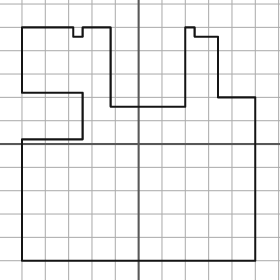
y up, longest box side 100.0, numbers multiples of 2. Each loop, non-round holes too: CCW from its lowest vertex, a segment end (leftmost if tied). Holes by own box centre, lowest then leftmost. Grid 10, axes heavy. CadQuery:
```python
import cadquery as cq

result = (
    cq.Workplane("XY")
    .moveTo(-50.0, -50.0)
    .lineTo(50.0, -50.0)
    .lineTo(50.0, 20.0)
    .lineTo(34.0, 20.0)
    .lineTo(34.0, 46.0)
    .lineTo(24.0, 46.0)
    .lineTo(24.0, 50.0)
    .lineTo(20.0, 50.0)
    .lineTo(20.0, 16.0)
    .lineTo(-12.0, 16.0)
    .lineTo(-12.0, 50.0)
    .lineTo(-24.0, 50.0)
    .lineTo(-24.0, 46.0)
    .lineTo(-28.0, 46.0)
    .lineTo(-28.0, 50.0)
    .lineTo(-50.0, 50.0)
    .lineTo(-50.0, 22.0)
    .lineTo(-24.0, 22.0)
    .lineTo(-24.0, 2.0)
    .lineTo(-50.0, 2.0)
    .close()
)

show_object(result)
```